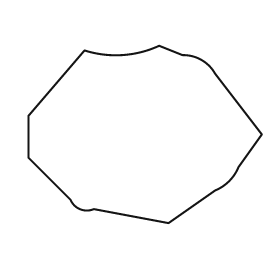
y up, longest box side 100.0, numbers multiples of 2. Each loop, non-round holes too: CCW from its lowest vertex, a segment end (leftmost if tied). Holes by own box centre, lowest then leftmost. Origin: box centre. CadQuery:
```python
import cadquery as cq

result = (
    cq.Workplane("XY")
    .moveTo(10.0, -38.0)
    .lineTo(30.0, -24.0)
    .threePointArc((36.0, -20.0), (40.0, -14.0))
    .lineTo(50.0, 0.0)
    .lineTo(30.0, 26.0)
    .threePointArc((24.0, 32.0), (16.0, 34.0))
    .lineTo(6.0, 38.0)
    .threePointArc((-10.0, 34.0), (-26.0, 36.0))
    .lineTo(-50.0, 8.0)
    .lineTo(-50.0, -10.0)
    .lineTo(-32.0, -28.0)
    .threePointArc((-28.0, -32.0), (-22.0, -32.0))
    .close()
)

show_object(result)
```